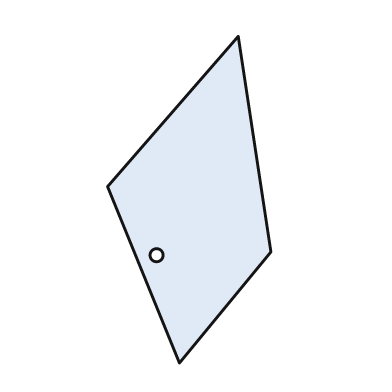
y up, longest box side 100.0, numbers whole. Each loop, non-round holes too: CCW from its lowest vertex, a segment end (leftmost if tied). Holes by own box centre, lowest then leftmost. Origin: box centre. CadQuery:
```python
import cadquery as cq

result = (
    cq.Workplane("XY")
    .moveTo(-3.0, -50.0)
    .lineTo(25.0, -16.0)
    .lineTo(15.0, 50.0)
    .lineTo(-25.0, 4.0)
    .close()
    .moveTo(-10.0, -17.0)
    .circle(2.0)
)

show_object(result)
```